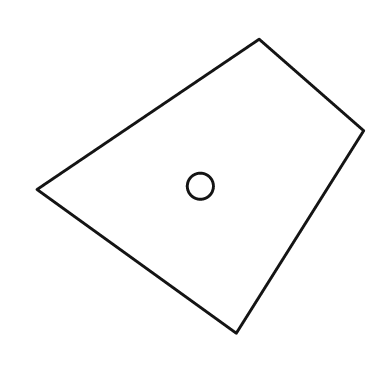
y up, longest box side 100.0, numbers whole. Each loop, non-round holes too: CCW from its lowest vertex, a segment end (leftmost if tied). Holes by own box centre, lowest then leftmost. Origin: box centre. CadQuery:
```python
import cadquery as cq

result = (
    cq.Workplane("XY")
    .moveTo(11.0, -45.0)
    .lineTo(50.0, 17.0)
    .lineTo(18.0, 45.0)
    .lineTo(-50.0, -1.0)
    .close()
    .moveTo(0.0, 0.0)
    .circle(4.0)
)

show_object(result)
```